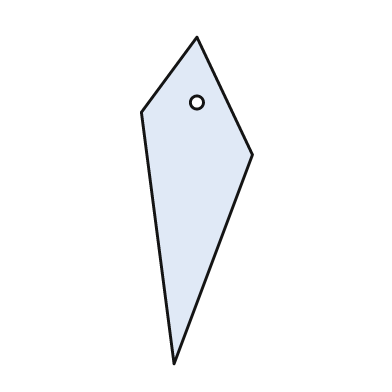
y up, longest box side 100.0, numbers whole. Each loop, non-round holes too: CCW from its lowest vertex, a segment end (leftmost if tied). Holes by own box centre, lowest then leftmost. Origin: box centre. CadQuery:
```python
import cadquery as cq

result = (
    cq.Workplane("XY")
    .moveTo(-7.0, -50.0)
    .lineTo(17.0, 14.0)
    .lineTo(0.0, 50.0)
    .lineTo(-17.0, 27.0)
    .close()
    .moveTo(0.0, 30.0)
    .circle(2.0)
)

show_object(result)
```